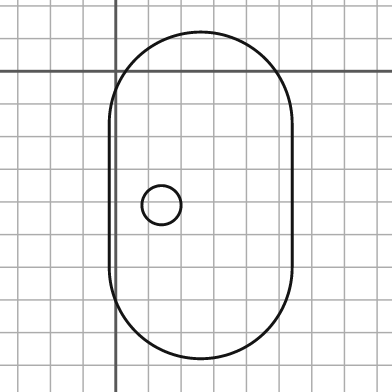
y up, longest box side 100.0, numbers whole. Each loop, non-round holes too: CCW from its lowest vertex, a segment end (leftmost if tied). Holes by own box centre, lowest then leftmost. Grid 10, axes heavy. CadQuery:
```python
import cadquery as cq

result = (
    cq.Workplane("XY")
    .moveTo(-2.0, -60.0)
    .threePointArc((26.0, -88.0), (54.0, -60.0))
    .lineTo(54.0, -16.0)
    .threePointArc((26.0, 12.0), (-2.0, -16.0))
    .close()
    .moveTo(14.0, -41.0)
    .circle(6.0)
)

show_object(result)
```